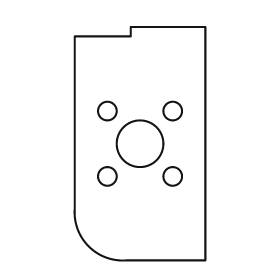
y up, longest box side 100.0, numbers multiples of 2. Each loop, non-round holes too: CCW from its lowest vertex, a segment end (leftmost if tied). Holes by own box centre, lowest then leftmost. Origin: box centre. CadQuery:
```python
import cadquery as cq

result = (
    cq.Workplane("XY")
    .moveTo(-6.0, -50.0)
    .lineTo(28.0, -50.0)
    .lineTo(28.0, 50.0)
    .lineTo(-4.0, 50.0)
    .lineTo(-4.0, 46.0)
    .lineTo(-28.0, 46.0)
    .lineTo(-28.0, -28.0)
    .threePointArc((-22.0, -44.0), (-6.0, -50.0))
    .close()
    .moveTo(-14.0, -14.0)
    .circle(4.0)
    .moveTo(14.0, -14.0)
    .circle(4.0)
    .moveTo(0.0, 0.0)
    .circle(10.0)
    .moveTo(-14.0, 14.0)
    .circle(4.0)
    .moveTo(14.0, 14.0)
    .circle(4.0)
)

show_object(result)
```